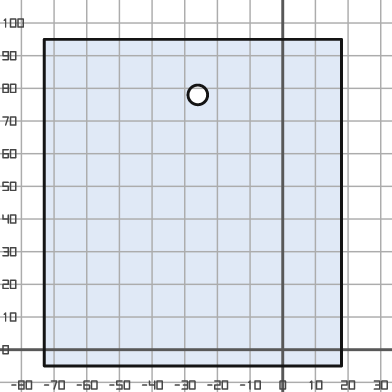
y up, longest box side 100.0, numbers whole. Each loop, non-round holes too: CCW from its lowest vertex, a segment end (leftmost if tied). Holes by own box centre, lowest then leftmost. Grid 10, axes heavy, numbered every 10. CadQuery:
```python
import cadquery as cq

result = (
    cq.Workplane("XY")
    .moveTo(-73.0, -5.0)
    .lineTo(18.0, -5.0)
    .lineTo(18.0, 95.0)
    .lineTo(-73.0, 95.0)
    .close()
    .moveTo(-26.0, 78.0)
    .circle(3.0)
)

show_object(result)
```